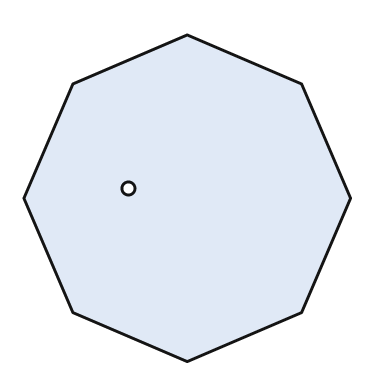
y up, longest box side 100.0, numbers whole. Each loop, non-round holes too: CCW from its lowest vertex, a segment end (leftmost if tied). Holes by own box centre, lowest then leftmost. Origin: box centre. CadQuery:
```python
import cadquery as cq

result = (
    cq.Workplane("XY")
    .moveTo(0.0, -50.0)
    .lineTo(35.0, -35.0)
    .lineTo(50.0, 0.0)
    .lineTo(35.0, 35.0)
    .lineTo(0.0, 50.0)
    .lineTo(-35.0, 35.0)
    .lineTo(-50.0, 0.0)
    .lineTo(-35.0, -35.0)
    .close()
    .moveTo(-18.0, 3.0)
    .circle(2.0)
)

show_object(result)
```